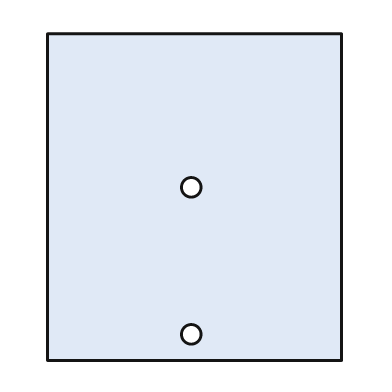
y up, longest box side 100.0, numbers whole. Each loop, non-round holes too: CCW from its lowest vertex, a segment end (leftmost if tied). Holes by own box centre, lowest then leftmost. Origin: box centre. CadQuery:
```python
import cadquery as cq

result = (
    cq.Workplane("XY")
    .moveTo(-45.0, -50.0)
    .lineTo(45.0, -50.0)
    .lineTo(45.0, 50.0)
    .lineTo(-45.0, 50.0)
    .close()
    .moveTo(-1.0, -42.0)
    .circle(3.0)
    .moveTo(-1.0, 3.0)
    .circle(3.0)
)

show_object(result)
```